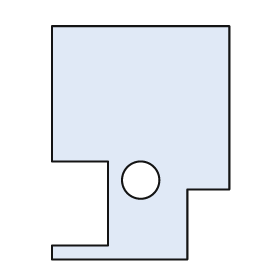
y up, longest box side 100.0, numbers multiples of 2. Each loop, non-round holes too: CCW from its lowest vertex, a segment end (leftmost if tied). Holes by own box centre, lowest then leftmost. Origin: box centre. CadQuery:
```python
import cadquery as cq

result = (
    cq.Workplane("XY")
    .moveTo(-38.0, -50.0)
    .lineTo(20.0, -50.0)
    .lineTo(20.0, -20.0)
    .lineTo(38.0, -20.0)
    .lineTo(38.0, 50.0)
    .lineTo(-38.0, 50.0)
    .lineTo(-38.0, -8.0)
    .lineTo(-14.0, -8.0)
    .lineTo(-14.0, -44.0)
    .lineTo(-38.0, -44.0)
    .close()
    .moveTo(0.0, -16.0)
    .circle(8.0)
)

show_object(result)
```